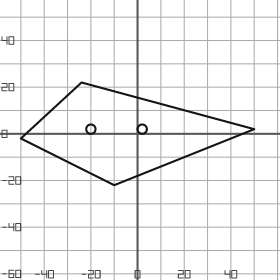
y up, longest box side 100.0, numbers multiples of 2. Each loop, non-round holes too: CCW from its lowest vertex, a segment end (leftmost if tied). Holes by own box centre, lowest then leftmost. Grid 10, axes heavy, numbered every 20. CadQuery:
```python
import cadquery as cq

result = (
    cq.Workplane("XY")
    .moveTo(-10.0, -22.0)
    .lineTo(50.0, 2.0)
    .lineTo(-24.0, 22.0)
    .lineTo(-50.0, -2.0)
    .close()
    .moveTo(-20.0, 2.0)
    .circle(2.0)
    .moveTo(2.0, 2.0)
    .circle(2.0)
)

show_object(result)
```